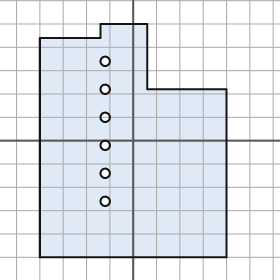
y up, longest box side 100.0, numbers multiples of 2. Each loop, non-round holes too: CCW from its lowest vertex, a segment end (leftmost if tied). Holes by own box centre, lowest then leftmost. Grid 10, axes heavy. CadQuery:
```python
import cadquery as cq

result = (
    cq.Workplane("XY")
    .moveTo(-40.0, -50.0)
    .lineTo(40.0, -50.0)
    .lineTo(40.0, 22.0)
    .lineTo(6.0, 22.0)
    .lineTo(6.0, 50.0)
    .lineTo(-14.0, 50.0)
    .lineTo(-14.0, 44.0)
    .lineTo(-40.0, 44.0)
    .close()
    .moveTo(-12.0, -26.0)
    .circle(2.0)
    .moveTo(-12.0, -14.0)
    .circle(2.0)
    .moveTo(-12.0, -2.0)
    .circle(2.0)
    .moveTo(-12.0, 10.0)
    .circle(2.0)
    .moveTo(-12.0, 22.0)
    .circle(2.0)
    .moveTo(-12.0, 34.0)
    .circle(2.0)
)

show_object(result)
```